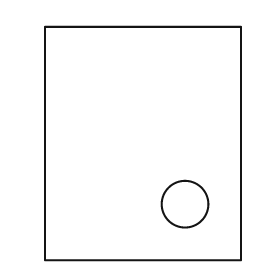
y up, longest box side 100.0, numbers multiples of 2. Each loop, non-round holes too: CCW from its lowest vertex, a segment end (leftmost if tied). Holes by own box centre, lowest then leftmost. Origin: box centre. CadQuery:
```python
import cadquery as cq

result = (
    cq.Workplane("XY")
    .moveTo(-42.0, -50.0)
    .lineTo(42.0, -50.0)
    .lineTo(42.0, 50.0)
    .lineTo(-42.0, 50.0)
    .close()
    .moveTo(18.0, -26.0)
    .circle(10.0)
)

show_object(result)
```